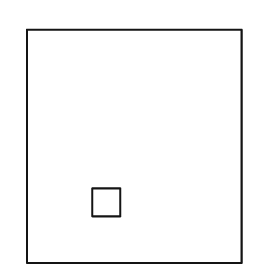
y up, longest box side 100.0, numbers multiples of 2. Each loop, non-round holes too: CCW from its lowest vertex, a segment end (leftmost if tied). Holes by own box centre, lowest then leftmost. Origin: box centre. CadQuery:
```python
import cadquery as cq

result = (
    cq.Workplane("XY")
    .moveTo(-46.0, -50.0)
    .lineTo(46.0, -50.0)
    .lineTo(46.0, 50.0)
    .lineTo(-46.0, 50.0)
    .close()
    .moveTo(-18.0, -30.0)
    .lineTo(-6.0, -30.0)
    .lineTo(-6.0, -18.0)
    .lineTo(-18.0, -18.0)
    .close()
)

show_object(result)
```